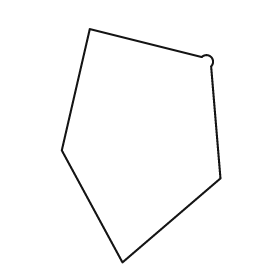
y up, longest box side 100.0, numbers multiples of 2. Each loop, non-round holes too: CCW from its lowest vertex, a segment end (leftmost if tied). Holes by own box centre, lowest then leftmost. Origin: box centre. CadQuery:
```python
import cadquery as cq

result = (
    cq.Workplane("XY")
    .moveTo(-8.0, -50.0)
    .lineTo(34.0, -14.0)
    .lineTo(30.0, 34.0)
    .threePointArc((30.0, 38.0), (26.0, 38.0))
    .lineTo(-22.0, 50.0)
    .lineTo(-34.0, -2.0)
    .close()
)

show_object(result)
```